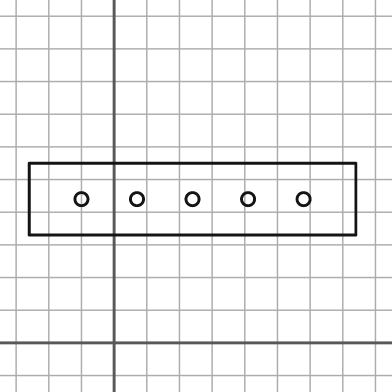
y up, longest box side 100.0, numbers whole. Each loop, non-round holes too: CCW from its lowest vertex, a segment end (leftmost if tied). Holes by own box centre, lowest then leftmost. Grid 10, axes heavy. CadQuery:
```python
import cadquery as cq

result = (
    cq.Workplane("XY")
    .moveTo(-26.0, 33.0)
    .lineTo(74.0, 33.0)
    .lineTo(74.0, 55.0)
    .lineTo(-26.0, 55.0)
    .close()
    .moveTo(-10.0, 44.0)
    .circle(2.0)
    .moveTo(7.0, 44.0)
    .circle(2.0)
    .moveTo(24.0, 44.0)
    .circle(2.0)
    .moveTo(41.0, 44.0)
    .circle(2.0)
    .moveTo(58.0, 44.0)
    .circle(2.0)
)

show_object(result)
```